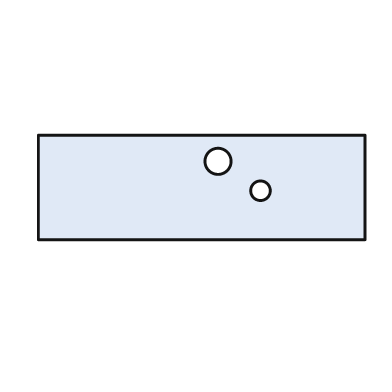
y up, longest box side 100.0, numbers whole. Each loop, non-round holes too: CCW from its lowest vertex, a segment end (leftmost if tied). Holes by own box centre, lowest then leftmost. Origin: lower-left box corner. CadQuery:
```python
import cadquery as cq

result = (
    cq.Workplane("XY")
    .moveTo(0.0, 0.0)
    .lineTo(100.0, 0.0)
    .lineTo(100.0, 32.0)
    .lineTo(0.0, 32.0)
    .close()
    .moveTo(68.0, 15.0)
    .circle(3.0)
    .moveTo(55.0, 24.0)
    .circle(4.0)
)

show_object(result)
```